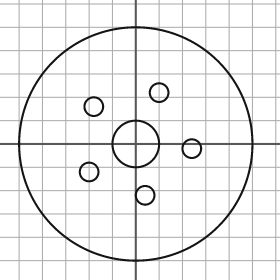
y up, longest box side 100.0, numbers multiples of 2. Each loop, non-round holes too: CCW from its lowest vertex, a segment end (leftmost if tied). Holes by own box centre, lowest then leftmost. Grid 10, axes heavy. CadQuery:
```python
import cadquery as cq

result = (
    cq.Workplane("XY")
    .moveTo(0.0, 0.0)
    .circle(50.0)
    .moveTo(4.0, -22.0)
    .circle(4.0)
    .moveTo(-20.0, -12.0)
    .circle(4.0)
    .moveTo(24.0, -2.0)
    .circle(4.0)
    .moveTo(0.0, 0.0)
    .circle(10.0)
    .moveTo(-18.0, 16.0)
    .circle(4.0)
    .moveTo(10.0, 22.0)
    .circle(4.0)
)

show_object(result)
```